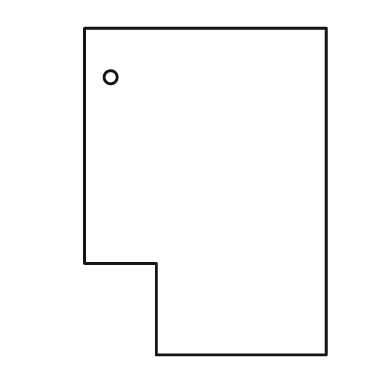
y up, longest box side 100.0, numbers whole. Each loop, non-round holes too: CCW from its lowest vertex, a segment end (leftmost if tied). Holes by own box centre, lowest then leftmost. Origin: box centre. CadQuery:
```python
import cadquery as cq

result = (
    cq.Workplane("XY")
    .moveTo(-15.0, -50.0)
    .lineTo(37.0, -50.0)
    .lineTo(37.0, 50.0)
    .lineTo(-37.0, 50.0)
    .lineTo(-37.0, -22.0)
    .lineTo(-15.0, -22.0)
    .close()
    .moveTo(-29.0, 35.0)
    .circle(2.0)
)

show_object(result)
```